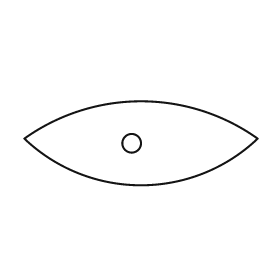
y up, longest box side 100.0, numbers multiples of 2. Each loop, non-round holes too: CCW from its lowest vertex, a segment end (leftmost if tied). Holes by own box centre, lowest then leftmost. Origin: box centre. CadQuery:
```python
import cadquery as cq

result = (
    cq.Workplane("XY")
    .moveTo(-50.0, 2.0)
    .threePointArc((0.0, -18.0), (50.0, 2.0))
    .threePointArc((0.0, 18.0), (-50.0, 2.0))
    .close()
    .moveTo(-4.0, 0.0)
    .circle(4.0)
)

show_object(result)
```